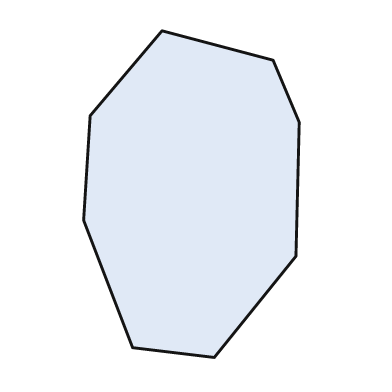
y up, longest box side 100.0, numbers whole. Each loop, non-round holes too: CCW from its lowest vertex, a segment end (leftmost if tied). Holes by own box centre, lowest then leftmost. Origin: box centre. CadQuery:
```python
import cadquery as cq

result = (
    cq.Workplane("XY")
    .moveTo(7.0, -50.0)
    .lineTo(32.0, -19.0)
    .lineTo(33.0, 22.0)
    .lineTo(25.0, 41.0)
    .lineTo(-9.0, 50.0)
    .lineTo(-31.0, 24.0)
    .lineTo(-33.0, -8.0)
    .lineTo(-18.0, -47.0)
    .close()
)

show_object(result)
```